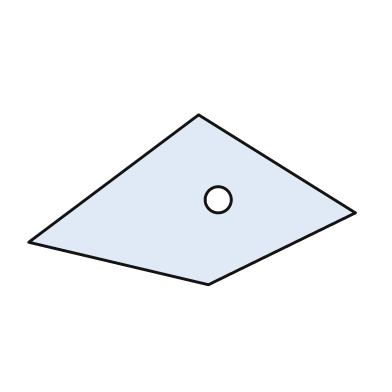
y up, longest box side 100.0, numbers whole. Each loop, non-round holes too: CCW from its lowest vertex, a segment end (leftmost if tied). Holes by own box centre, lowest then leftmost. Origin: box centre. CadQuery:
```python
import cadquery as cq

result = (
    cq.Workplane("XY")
    .moveTo(5.0, -26.0)
    .lineTo(50.0, -4.0)
    .lineTo(2.0, 26.0)
    .lineTo(-50.0, -13.0)
    .close()
    .moveTo(8.0, 0.0)
    .circle(4.0)
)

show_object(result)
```